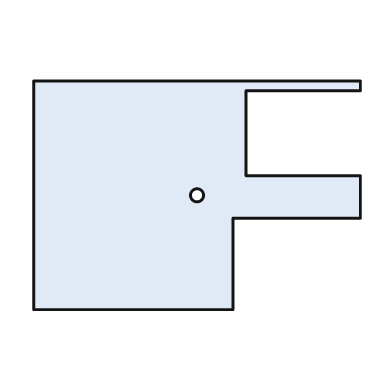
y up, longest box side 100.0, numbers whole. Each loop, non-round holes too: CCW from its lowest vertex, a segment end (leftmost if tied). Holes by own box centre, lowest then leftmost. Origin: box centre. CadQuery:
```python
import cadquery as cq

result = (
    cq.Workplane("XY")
    .moveTo(-50.0, -35.0)
    .lineTo(11.0, -35.0)
    .lineTo(11.0, -7.0)
    .lineTo(50.0, -7.0)
    .lineTo(50.0, 6.0)
    .lineTo(15.0, 6.0)
    .lineTo(15.0, 32.0)
    .lineTo(50.0, 32.0)
    .lineTo(50.0, 35.0)
    .lineTo(-50.0, 35.0)
    .close()
    .moveTo(0.0, 0.0)
    .circle(2.0)
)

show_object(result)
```